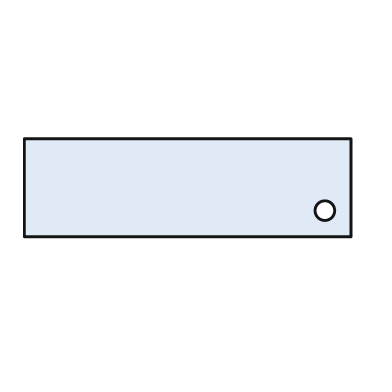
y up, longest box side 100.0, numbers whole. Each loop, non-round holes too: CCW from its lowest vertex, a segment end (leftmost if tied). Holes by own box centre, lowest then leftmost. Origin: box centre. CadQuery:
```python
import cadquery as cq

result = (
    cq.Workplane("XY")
    .moveTo(-50.0, -15.0)
    .lineTo(50.0, -15.0)
    .lineTo(50.0, 15.0)
    .lineTo(-50.0, 15.0)
    .close()
    .moveTo(42.0, -7.0)
    .circle(3.0)
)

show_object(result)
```